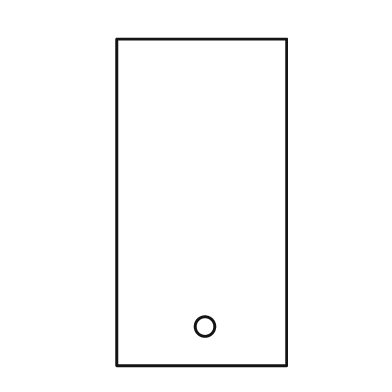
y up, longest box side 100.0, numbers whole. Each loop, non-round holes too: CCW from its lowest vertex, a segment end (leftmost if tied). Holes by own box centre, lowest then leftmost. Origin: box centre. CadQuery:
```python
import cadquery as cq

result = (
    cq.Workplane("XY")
    .moveTo(-26.0, -50.0)
    .lineTo(26.0, -50.0)
    .lineTo(26.0, 50.0)
    .lineTo(-26.0, 50.0)
    .close()
    .moveTo(1.0, -38.0)
    .circle(3.0)
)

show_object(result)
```